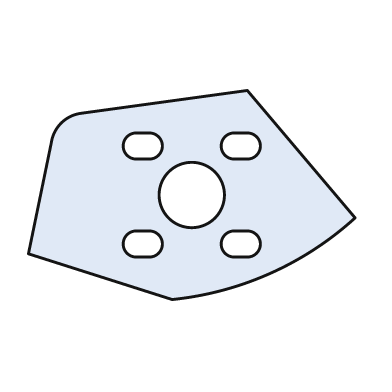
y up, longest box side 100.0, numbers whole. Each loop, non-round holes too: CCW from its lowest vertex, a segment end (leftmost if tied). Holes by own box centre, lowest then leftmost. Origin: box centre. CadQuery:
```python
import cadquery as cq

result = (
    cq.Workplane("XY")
    .moveTo(-6.0, -32.0)
    .threePointArc((24.0, -24.0), (50.0, -7.0))
    .lineTo(17.0, 32.0)
    .lineTo(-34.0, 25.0)
    .threePointArc((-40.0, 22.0), (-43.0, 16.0))
    .lineTo(-50.0, -18.0)
    .close()
    .moveTo(-17.0, -19.0)
    .lineTo(-13.0, -19.0)
    .threePointArc((-9.0, -15.0), (-13.0, -11.0))
    .lineTo(-17.0, -11.0)
    .threePointArc((-21.0, -15.0), (-17.0, -19.0))
    .close()
    .moveTo(13.0, -19.0)
    .lineTo(17.0, -19.0)
    .threePointArc((21.0, -15.0), (17.0, -11.0))
    .lineTo(13.0, -11.0)
    .threePointArc((9.0, -15.0), (13.0, -19.0))
    .close()
    .moveTo(0.0, 0.0)
    .circle(10.0)
    .moveTo(-17.0, 11.0)
    .lineTo(-13.0, 11.0)
    .threePointArc((-9.0, 15.0), (-13.0, 19.0))
    .lineTo(-17.0, 19.0)
    .threePointArc((-21.0, 15.0), (-17.0, 11.0))
    .close()
    .moveTo(13.0, 11.0)
    .lineTo(17.0, 11.0)
    .threePointArc((21.0, 15.0), (17.0, 19.0))
    .lineTo(13.0, 19.0)
    .threePointArc((9.0, 15.0), (13.0, 11.0))
    .close()
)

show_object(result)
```